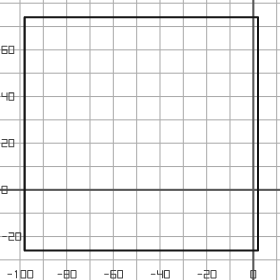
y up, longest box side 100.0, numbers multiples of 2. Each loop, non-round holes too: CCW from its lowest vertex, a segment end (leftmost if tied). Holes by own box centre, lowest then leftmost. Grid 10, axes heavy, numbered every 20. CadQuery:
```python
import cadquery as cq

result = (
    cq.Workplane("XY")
    .moveTo(-98.0, -26.0)
    .lineTo(2.0, -26.0)
    .lineTo(2.0, 74.0)
    .lineTo(-98.0, 74.0)
    .close()
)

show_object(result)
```